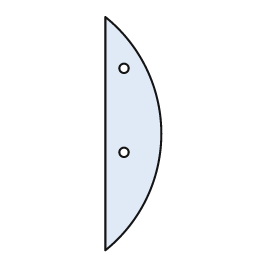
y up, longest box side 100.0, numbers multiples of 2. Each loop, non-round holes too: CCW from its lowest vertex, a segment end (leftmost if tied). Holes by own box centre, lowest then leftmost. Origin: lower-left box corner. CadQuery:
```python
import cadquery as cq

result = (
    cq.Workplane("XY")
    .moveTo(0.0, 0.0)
    .threePointArc((24.0, 50.0), (0.0, 100.0))
    .close()
    .moveTo(8.0, 42.0)
    .circle(2.0)
    .moveTo(8.0, 78.0)
    .circle(2.0)
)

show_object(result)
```